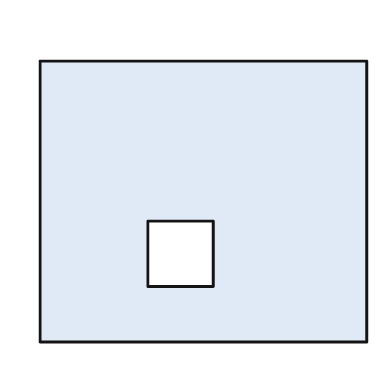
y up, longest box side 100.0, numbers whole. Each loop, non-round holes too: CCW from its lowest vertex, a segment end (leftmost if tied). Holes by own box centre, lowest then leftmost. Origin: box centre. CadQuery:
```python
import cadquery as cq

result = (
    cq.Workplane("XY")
    .moveTo(-50.0, -43.0)
    .lineTo(50.0, -43.0)
    .lineTo(50.0, 43.0)
    .lineTo(-50.0, 43.0)
    .close()
    .moveTo(-17.0, -26.0)
    .lineTo(3.0, -26.0)
    .lineTo(3.0, -6.0)
    .lineTo(-17.0, -6.0)
    .close()
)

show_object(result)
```